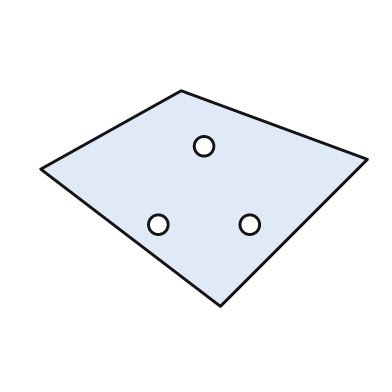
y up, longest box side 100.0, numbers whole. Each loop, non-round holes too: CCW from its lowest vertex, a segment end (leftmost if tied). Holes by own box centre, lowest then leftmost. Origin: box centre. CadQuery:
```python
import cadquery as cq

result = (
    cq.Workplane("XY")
    .moveTo(5.0, -33.0)
    .lineTo(50.0, 12.0)
    .lineTo(-7.0, 33.0)
    .lineTo(-50.0, 9.0)
    .close()
    .moveTo(-14.0, -8.0)
    .circle(3.0)
    .moveTo(14.0, -8.0)
    .circle(3.0)
    .moveTo(0.0, 16.0)
    .circle(3.0)
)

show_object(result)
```